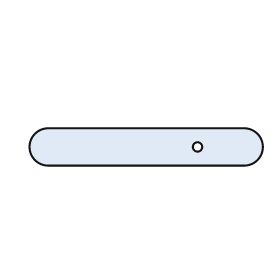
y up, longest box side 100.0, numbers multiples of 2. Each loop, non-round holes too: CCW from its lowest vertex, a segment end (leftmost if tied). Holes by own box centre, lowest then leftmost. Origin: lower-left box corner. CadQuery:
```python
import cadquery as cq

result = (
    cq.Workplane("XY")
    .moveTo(8.0, 0.0)
    .lineTo(92.0, 0.0)
    .threePointArc((100.0, 8.0), (92.0, 16.0))
    .lineTo(8.0, 16.0)
    .threePointArc((0.0, 8.0), (8.0, 0.0))
    .close()
    .moveTo(72.0, 8.0)
    .circle(2.0)
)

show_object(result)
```